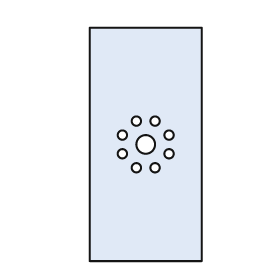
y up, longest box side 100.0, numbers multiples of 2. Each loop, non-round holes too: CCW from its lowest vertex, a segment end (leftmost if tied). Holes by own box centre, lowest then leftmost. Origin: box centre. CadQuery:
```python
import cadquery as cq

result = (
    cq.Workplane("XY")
    .moveTo(-24.0, -50.0)
    .lineTo(24.0, -50.0)
    .lineTo(24.0, 50.0)
    .lineTo(-24.0, 50.0)
    .close()
    .moveTo(-4.0, -10.0)
    .circle(2.0)
    .moveTo(4.0, -10.0)
    .circle(2.0)
    .moveTo(-10.0, -4.0)
    .circle(2.0)
    .moveTo(10.0, -4.0)
    .circle(2.0)
    .moveTo(0.0, 0.0)
    .circle(4.0)
    .moveTo(-10.0, 4.0)
    .circle(2.0)
    .moveTo(10.0, 4.0)
    .circle(2.0)
    .moveTo(-4.0, 10.0)
    .circle(2.0)
    .moveTo(4.0, 10.0)
    .circle(2.0)
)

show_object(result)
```